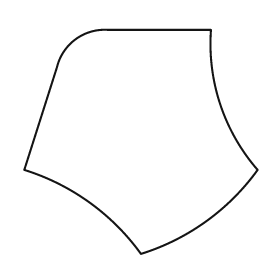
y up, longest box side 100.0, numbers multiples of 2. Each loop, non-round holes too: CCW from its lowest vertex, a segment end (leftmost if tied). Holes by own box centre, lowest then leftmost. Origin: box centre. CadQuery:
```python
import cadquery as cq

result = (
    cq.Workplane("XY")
    .moveTo(0.0, -48.0)
    .threePointArc((28.0, -34.0), (50.0, -12.0))
    .threePointArc((34.0, 16.0), (30.0, 48.0))
    .lineTo(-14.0, 48.0)
    .threePointArc((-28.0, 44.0), (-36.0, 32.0))
    .lineTo(-50.0, -12.0)
    .threePointArc((-22.0, -26.0), (0.0, -48.0))
    .close()
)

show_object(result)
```